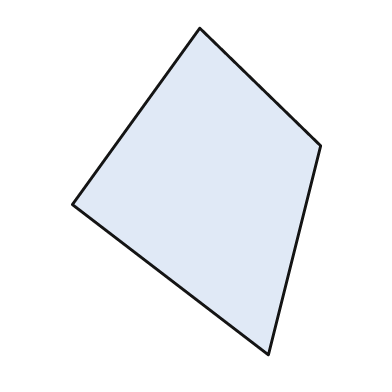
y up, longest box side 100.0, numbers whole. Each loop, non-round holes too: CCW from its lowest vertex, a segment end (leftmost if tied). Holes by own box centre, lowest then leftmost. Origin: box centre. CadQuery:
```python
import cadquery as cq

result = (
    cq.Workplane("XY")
    .moveTo(22.0, -50.0)
    .lineTo(38.0, 14.0)
    .lineTo(1.0, 50.0)
    .lineTo(-38.0, -4.0)
    .close()
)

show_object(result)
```